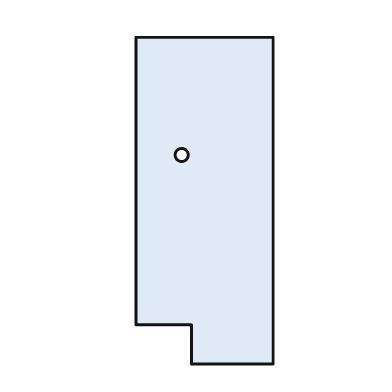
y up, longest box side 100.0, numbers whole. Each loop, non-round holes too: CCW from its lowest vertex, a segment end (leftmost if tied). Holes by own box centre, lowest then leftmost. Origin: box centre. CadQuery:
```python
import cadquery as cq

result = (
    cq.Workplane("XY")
    .moveTo(-4.0, -50.0)
    .lineTo(21.0, -50.0)
    .lineTo(21.0, 50.0)
    .lineTo(-21.0, 50.0)
    .lineTo(-21.0, -38.0)
    .lineTo(-4.0, -38.0)
    .close()
    .moveTo(-7.0, 14.0)
    .circle(2.0)
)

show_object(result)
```